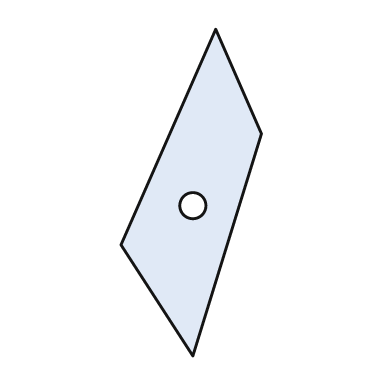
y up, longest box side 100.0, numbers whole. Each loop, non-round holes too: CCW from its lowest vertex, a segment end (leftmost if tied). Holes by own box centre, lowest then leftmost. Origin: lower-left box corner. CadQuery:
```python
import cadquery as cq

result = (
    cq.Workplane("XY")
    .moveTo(22.0, 0.0)
    .lineTo(43.0, 68.0)
    .lineTo(29.0, 100.0)
    .lineTo(0.0, 34.0)
    .close()
    .moveTo(22.0, 46.0)
    .circle(4.0)
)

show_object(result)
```